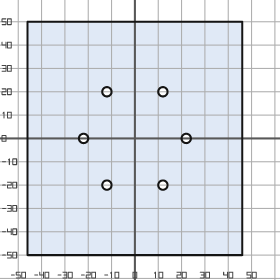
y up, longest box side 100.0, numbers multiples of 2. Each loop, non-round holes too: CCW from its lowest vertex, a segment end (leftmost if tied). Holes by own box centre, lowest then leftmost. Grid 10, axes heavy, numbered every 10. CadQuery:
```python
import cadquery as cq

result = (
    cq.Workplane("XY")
    .moveTo(-46.0, -50.0)
    .lineTo(46.0, -50.0)
    .lineTo(46.0, 50.0)
    .lineTo(-46.0, 50.0)
    .close()
    .moveTo(-12.0, -20.0)
    .circle(2.0)
    .moveTo(12.0, -20.0)
    .circle(2.0)
    .moveTo(-22.0, 0.0)
    .circle(2.0)
    .moveTo(22.0, 0.0)
    .circle(2.0)
    .moveTo(-12.0, 20.0)
    .circle(2.0)
    .moveTo(12.0, 20.0)
    .circle(2.0)
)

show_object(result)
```